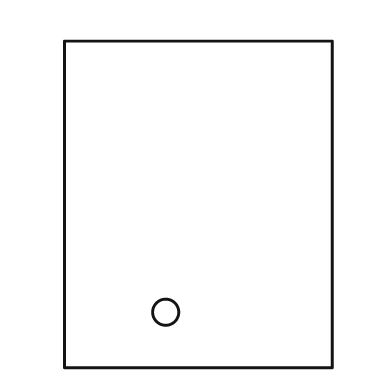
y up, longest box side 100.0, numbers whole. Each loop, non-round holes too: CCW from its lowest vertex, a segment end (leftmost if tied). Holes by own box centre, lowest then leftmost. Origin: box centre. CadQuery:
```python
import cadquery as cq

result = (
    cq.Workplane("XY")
    .moveTo(-41.0, -50.0)
    .lineTo(41.0, -50.0)
    .lineTo(41.0, 50.0)
    .lineTo(-41.0, 50.0)
    .close()
    .moveTo(-10.0, -33.0)
    .circle(4.0)
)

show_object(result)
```